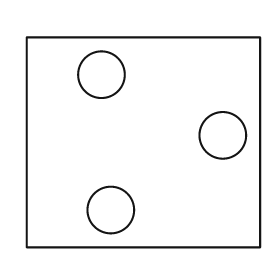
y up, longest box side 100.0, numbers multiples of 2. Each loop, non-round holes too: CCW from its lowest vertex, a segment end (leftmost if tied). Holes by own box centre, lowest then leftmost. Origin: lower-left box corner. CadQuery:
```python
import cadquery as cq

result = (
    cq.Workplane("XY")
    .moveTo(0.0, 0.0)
    .lineTo(100.0, 0.0)
    .lineTo(100.0, 90.0)
    .lineTo(0.0, 90.0)
    .close()
    .moveTo(36.0, 16.0)
    .circle(10.0)
    .moveTo(84.0, 48.0)
    .circle(10.0)
    .moveTo(32.0, 74.0)
    .circle(10.0)
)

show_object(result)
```